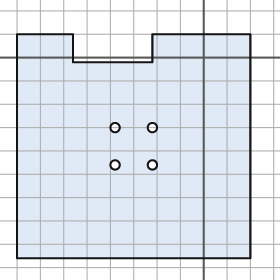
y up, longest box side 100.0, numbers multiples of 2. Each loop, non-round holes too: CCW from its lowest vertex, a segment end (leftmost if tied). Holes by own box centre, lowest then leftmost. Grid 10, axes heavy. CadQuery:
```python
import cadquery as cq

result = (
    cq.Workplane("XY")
    .moveTo(-80.0, -86.0)
    .lineTo(20.0, -86.0)
    .lineTo(20.0, 10.0)
    .lineTo(-22.0, 10.0)
    .lineTo(-22.0, -2.0)
    .lineTo(-56.0, -2.0)
    .lineTo(-56.0, 10.0)
    .lineTo(-80.0, 10.0)
    .close()
    .moveTo(-38.0, -46.0)
    .circle(2.0)
    .moveTo(-22.0, -46.0)
    .circle(2.0)
    .moveTo(-38.0, -30.0)
    .circle(2.0)
    .moveTo(-22.0, -30.0)
    .circle(2.0)
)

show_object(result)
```